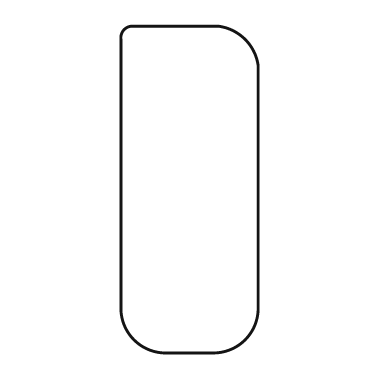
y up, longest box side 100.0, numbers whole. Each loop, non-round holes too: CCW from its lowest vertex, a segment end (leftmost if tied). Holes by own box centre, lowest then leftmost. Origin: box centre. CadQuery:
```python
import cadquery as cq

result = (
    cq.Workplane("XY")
    .moveTo(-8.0, -50.0)
    .lineTo(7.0, -50.0)
    .threePointArc((17.0, -46.0), (21.0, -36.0))
    .lineTo(21.0, 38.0)
    .threePointArc((17.0, 46.0), (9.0, 50.0))
    .lineTo(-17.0, 50.0)
    .threePointArc((-20.0, 49.0), (-21.0, 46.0))
    .lineTo(-21.0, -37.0)
    .threePointArc((-17.0, -46.0), (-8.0, -50.0))
    .close()
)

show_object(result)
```